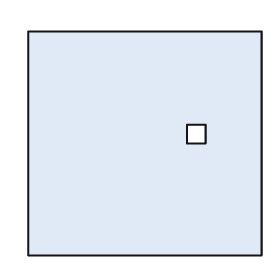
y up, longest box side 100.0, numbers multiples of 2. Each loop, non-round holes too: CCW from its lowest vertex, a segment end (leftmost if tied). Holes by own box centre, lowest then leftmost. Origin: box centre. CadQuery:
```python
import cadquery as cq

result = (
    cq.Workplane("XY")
    .moveTo(-50.0, -48.0)
    .lineTo(50.0, -48.0)
    .lineTo(50.0, 48.0)
    .lineTo(-50.0, 48.0)
    .close()
    .moveTo(18.0, 0.0)
    .lineTo(26.0, 0.0)
    .lineTo(26.0, 8.0)
    .lineTo(18.0, 8.0)
    .close()
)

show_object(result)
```